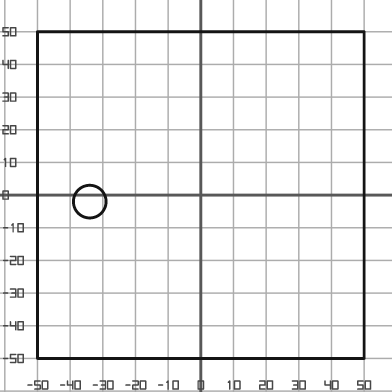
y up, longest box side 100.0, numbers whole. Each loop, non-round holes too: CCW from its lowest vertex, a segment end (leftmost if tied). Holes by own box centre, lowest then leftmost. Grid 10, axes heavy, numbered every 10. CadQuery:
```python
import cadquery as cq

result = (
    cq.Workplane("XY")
    .moveTo(-50.0, -50.0)
    .lineTo(50.0, -50.0)
    .lineTo(50.0, 50.0)
    .lineTo(-50.0, 50.0)
    .close()
    .moveTo(-34.0, -2.0)
    .circle(5.0)
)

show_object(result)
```